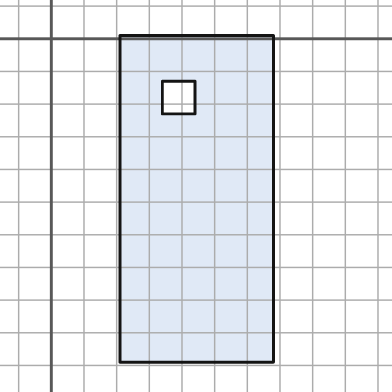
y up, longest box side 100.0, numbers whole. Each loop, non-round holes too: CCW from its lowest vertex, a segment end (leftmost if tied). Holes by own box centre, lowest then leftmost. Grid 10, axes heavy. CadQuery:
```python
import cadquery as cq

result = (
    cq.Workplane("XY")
    .moveTo(21.0, -99.0)
    .lineTo(68.0, -99.0)
    .lineTo(68.0, 1.0)
    .lineTo(21.0, 1.0)
    .close()
    .moveTo(34.0, -23.0)
    .lineTo(44.0, -23.0)
    .lineTo(44.0, -13.0)
    .lineTo(34.0, -13.0)
    .close()
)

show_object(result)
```